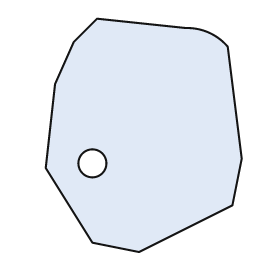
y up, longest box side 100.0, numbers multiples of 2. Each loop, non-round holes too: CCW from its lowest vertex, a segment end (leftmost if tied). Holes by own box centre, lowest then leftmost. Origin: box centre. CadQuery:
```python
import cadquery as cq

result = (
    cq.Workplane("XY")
    .moveTo(-2.0, -50.0)
    .lineTo(38.0, -30.0)
    .lineTo(42.0, -10.0)
    .lineTo(36.0, 38.0)
    .threePointArc((28.0, 44.0), (18.0, 46.0))
    .lineTo(-20.0, 50.0)
    .lineTo(-30.0, 40.0)
    .lineTo(-38.0, 22.0)
    .lineTo(-42.0, -14.0)
    .lineTo(-22.0, -46.0)
    .close()
    .moveTo(-22.0, -12.0)
    .circle(6.0)
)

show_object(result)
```